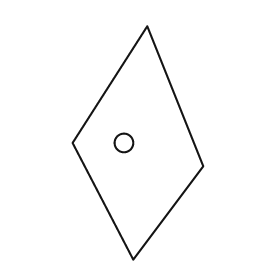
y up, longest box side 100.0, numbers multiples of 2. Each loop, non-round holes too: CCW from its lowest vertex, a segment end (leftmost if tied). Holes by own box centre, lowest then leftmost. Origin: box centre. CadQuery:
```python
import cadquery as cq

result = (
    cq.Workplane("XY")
    .moveTo(-2.0, -50.0)
    .lineTo(28.0, -10.0)
    .lineTo(4.0, 50.0)
    .lineTo(-28.0, 0.0)
    .close()
    .moveTo(-6.0, 0.0)
    .circle(4.0)
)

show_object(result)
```